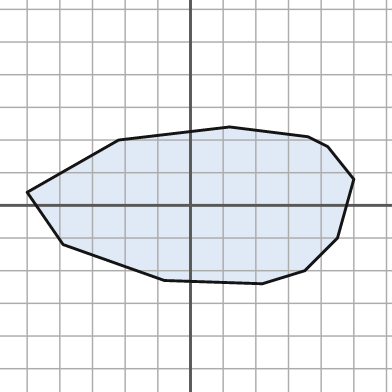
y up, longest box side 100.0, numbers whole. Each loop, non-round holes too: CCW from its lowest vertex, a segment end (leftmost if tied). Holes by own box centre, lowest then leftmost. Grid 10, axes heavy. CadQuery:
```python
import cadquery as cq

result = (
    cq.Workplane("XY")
    .moveTo(22.0, -24.0)
    .lineTo(35.0, -20.0)
    .lineTo(45.0, -10.0)
    .lineTo(50.0, 8.0)
    .lineTo(42.0, 18.0)
    .lineTo(36.0, 21.0)
    .lineTo(12.0, 24.0)
    .lineTo(-22.0, 20.0)
    .lineTo(-50.0, 4.0)
    .lineTo(-39.0, -12.0)
    .lineTo(-8.0, -23.0)
    .close()
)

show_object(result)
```